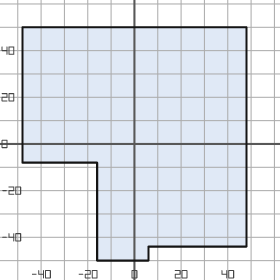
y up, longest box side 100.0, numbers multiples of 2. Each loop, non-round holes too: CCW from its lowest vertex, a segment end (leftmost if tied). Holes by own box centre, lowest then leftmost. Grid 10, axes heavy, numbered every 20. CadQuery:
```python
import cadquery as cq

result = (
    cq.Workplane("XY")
    .moveTo(-16.0, -50.0)
    .lineTo(6.0, -50.0)
    .lineTo(6.0, -44.0)
    .lineTo(48.0, -44.0)
    .lineTo(48.0, 50.0)
    .lineTo(-48.0, 50.0)
    .lineTo(-48.0, -8.0)
    .lineTo(-16.0, -8.0)
    .close()
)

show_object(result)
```